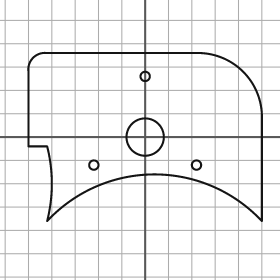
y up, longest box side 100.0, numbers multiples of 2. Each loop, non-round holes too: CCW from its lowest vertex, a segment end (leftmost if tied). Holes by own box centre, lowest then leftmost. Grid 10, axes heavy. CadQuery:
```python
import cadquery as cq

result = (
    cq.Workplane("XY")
    .moveTo(-42.0, -36.0)
    .threePointArc((4.0, -16.0), (50.0, -36.0))
    .lineTo(50.0, 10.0)
    .threePointArc((42.0, 28.0), (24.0, 36.0))
    .lineTo(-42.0, 36.0)
    .threePointArc((-48.0, 34.0), (-50.0, 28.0))
    .lineTo(-50.0, -4.0)
    .lineTo(-42.0, -4.0)
    .threePointArc((-40.0, -20.0), (-42.0, -36.0))
    .close()
    .moveTo(-22.0, -12.0)
    .circle(2.0)
    .moveTo(22.0, -12.0)
    .circle(2.0)
    .moveTo(0.0, 0.0)
    .circle(8.0)
    .moveTo(0.0, 26.0)
    .circle(2.0)
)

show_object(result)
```